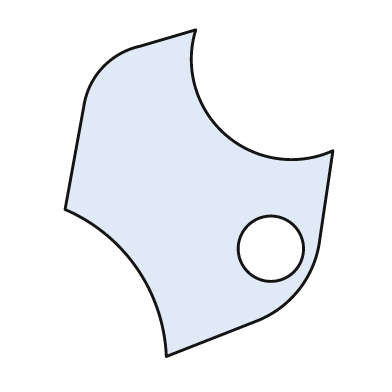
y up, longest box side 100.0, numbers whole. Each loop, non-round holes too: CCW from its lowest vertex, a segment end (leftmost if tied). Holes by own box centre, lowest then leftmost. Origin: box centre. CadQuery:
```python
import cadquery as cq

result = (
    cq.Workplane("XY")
    .moveTo(-10.0, -50.0)
    .lineTo(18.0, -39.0)
    .threePointArc((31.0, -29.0), (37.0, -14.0))
    .lineTo(41.0, 13.0)
    .threePointArc((8.0, 18.0), (-1.0, 50.0))
    .lineTo(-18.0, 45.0)
    .threePointArc((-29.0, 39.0), (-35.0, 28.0))
    .lineTo(-41.0, -5.0)
    .threePointArc((-19.0, -23.0), (-10.0, -50.0))
    .close()
    .moveTo(22.0, -17.0)
    .circle(10.0)
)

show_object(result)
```